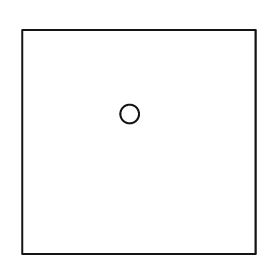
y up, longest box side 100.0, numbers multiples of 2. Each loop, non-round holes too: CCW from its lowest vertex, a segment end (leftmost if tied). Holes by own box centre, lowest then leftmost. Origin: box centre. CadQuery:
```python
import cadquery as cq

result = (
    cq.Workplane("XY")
    .moveTo(-50.0, -48.0)
    .lineTo(50.0, -48.0)
    .lineTo(50.0, 48.0)
    .lineTo(-50.0, 48.0)
    .close()
    .moveTo(-4.0, 12.0)
    .circle(4.0)
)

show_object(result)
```